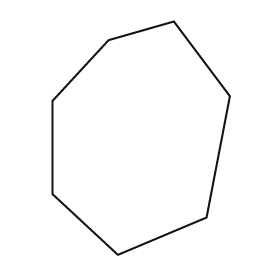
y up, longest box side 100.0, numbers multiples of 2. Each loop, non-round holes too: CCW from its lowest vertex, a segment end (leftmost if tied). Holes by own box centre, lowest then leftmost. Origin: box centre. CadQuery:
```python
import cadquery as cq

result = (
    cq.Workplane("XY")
    .moveTo(-10.0, -50.0)
    .lineTo(28.0, -34.0)
    .lineTo(38.0, 18.0)
    .lineTo(14.0, 50.0)
    .lineTo(-14.0, 42.0)
    .lineTo(-38.0, 16.0)
    .lineTo(-38.0, -24.0)
    .close()
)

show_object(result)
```